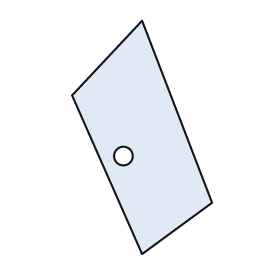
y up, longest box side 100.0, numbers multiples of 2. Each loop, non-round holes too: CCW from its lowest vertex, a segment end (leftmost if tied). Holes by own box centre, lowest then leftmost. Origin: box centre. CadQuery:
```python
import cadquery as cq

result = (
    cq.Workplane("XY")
    .moveTo(0.0, -50.0)
    .lineTo(30.0, -28.0)
    .lineTo(0.0, 50.0)
    .lineTo(-30.0, 18.0)
    .close()
    .moveTo(-8.0, -8.0)
    .circle(4.0)
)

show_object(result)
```